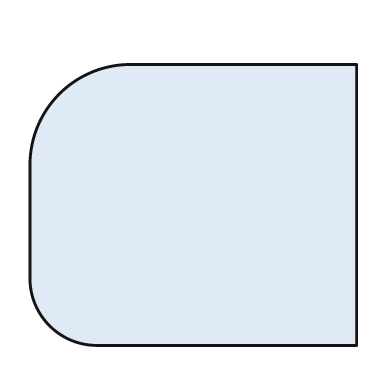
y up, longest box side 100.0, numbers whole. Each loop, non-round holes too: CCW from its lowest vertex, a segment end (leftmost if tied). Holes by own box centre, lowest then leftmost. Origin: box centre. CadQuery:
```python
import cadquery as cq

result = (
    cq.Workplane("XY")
    .moveTo(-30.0, -43.0)
    .lineTo(50.0, -43.0)
    .lineTo(50.0, 43.0)
    .lineTo(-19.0, 43.0)
    .threePointArc((-41.0, 34.0), (-50.0, 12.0))
    .lineTo(-50.0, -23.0)
    .threePointArc((-44.0, -37.0), (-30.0, -43.0))
    .close()
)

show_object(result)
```